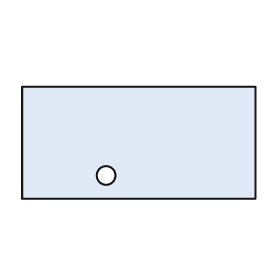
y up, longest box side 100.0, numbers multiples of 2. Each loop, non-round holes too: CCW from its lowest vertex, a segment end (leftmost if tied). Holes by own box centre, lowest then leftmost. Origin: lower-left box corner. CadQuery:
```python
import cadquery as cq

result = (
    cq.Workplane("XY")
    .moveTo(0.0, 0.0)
    .lineTo(100.0, 0.0)
    .lineTo(100.0, 48.0)
    .lineTo(0.0, 48.0)
    .close()
    .moveTo(36.0, 10.0)
    .circle(4.0)
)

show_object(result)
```